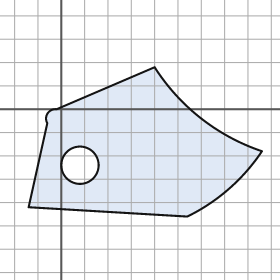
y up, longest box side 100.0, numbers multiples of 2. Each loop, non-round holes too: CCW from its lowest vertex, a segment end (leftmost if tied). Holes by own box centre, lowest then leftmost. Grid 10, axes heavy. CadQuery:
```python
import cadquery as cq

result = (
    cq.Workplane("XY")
    .moveTo(54.0, -46.0)
    .threePointArc((72.0, -34.0), (86.0, -18.0))
    .threePointArc((60.0, -4.0), (40.0, 18.0))
    .lineTo(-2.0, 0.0)
    .threePointArc((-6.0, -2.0), (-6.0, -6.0))
    .lineTo(-14.0, -42.0)
    .close()
    .moveTo(8.0, -24.0)
    .circle(8.0)
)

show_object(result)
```